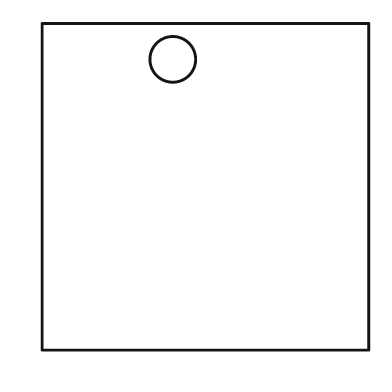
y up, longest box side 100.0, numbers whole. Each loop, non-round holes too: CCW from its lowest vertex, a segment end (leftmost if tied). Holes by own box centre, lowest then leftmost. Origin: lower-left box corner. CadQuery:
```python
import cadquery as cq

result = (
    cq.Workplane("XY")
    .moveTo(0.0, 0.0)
    .lineTo(100.0, 0.0)
    .lineTo(100.0, 100.0)
    .lineTo(0.0, 100.0)
    .close()
    .moveTo(40.0, 89.0)
    .circle(7.0)
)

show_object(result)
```